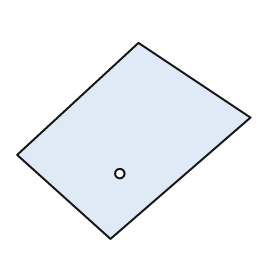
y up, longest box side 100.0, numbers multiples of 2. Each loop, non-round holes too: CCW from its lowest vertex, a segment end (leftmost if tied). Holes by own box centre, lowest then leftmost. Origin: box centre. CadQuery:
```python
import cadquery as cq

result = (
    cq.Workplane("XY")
    .moveTo(-10.0, -42.0)
    .lineTo(50.0, 10.0)
    .lineTo(2.0, 42.0)
    .lineTo(-50.0, -6.0)
    .close()
    .moveTo(-6.0, -14.0)
    .circle(2.0)
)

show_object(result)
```